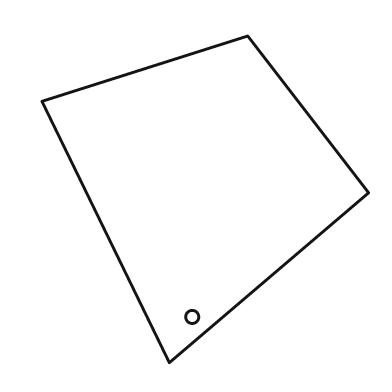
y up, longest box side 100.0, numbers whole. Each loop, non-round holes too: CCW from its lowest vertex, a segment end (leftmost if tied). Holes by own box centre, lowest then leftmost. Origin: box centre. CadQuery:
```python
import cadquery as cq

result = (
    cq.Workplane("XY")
    .moveTo(-11.0, -50.0)
    .lineTo(50.0, 2.0)
    .lineTo(13.0, 50.0)
    .lineTo(-50.0, 30.0)
    .close()
    .moveTo(-4.0, -36.0)
    .circle(2.0)
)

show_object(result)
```